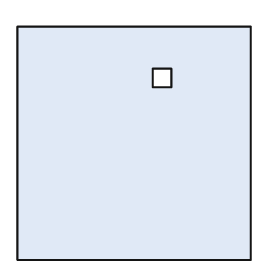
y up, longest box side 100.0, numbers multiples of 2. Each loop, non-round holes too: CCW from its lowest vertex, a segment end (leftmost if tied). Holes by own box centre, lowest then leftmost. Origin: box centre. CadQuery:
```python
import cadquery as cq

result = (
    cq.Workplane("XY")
    .moveTo(-50.0, -50.0)
    .lineTo(50.0, -50.0)
    .lineTo(50.0, 50.0)
    .lineTo(-50.0, 50.0)
    .close()
    .moveTo(8.0, 24.0)
    .lineTo(16.0, 24.0)
    .lineTo(16.0, 32.0)
    .lineTo(8.0, 32.0)
    .close()
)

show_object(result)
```